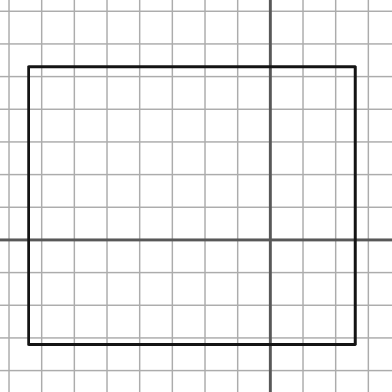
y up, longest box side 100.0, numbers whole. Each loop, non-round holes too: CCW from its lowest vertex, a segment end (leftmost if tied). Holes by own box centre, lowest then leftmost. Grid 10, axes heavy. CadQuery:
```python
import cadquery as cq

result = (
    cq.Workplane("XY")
    .moveTo(-74.0, -32.0)
    .lineTo(26.0, -32.0)
    .lineTo(26.0, 53.0)
    .lineTo(-74.0, 53.0)
    .close()
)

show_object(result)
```